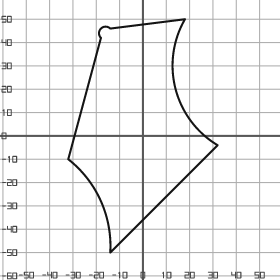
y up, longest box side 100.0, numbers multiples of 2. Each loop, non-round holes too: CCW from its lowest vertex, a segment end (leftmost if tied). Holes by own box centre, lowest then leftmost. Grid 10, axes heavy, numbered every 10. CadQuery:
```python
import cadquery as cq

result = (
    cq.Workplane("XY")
    .moveTo(-14.0, -50.0)
    .lineTo(32.0, -4.0)
    .threePointArc((14.0, 20.0), (18.0, 50.0))
    .lineTo(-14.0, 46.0)
    .threePointArc((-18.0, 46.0), (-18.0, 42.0))
    .lineTo(-32.0, -10.0)
    .threePointArc((-18.0, -28.0), (-14.0, -50.0))
    .close()
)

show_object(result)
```